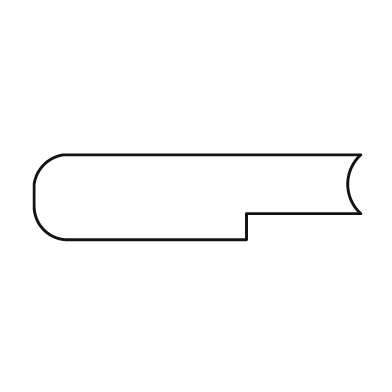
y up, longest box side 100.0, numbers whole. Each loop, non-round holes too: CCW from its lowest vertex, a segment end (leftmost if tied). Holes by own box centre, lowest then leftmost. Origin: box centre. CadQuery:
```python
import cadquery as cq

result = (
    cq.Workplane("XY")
    .moveTo(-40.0, -13.0)
    .lineTo(15.0, -13.0)
    .lineTo(15.0, -5.0)
    .lineTo(50.0, -5.0)
    .threePointArc((46.0, 4.0), (50.0, 13.0))
    .lineTo(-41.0, 13.0)
    .threePointArc((-47.0, 10.0), (-50.0, 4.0))
    .lineTo(-50.0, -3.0)
    .threePointArc((-47.0, -10.0), (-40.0, -13.0))
    .close()
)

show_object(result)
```